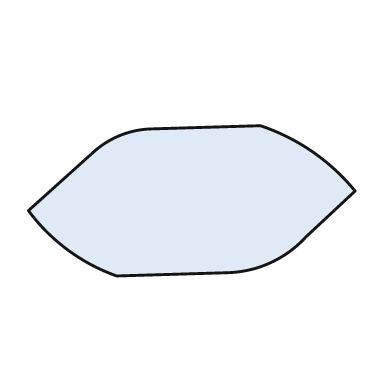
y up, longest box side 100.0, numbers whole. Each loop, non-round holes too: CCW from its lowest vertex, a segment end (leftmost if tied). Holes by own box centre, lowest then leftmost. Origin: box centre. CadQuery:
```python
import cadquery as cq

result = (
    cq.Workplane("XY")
    .moveTo(-23.0, -23.0)
    .lineTo(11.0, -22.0)
    .threePointArc((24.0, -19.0), (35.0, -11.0))
    .lineTo(50.0, 3.0)
    .threePointArc((37.0, 15.0), (21.0, 23.0))
    .lineTo(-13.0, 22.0)
    .threePointArc((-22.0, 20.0), (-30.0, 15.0))
    .lineTo(-50.0, -3.0)
    .threePointArc((-38.0, -15.0), (-23.0, -23.0))
    .close()
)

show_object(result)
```